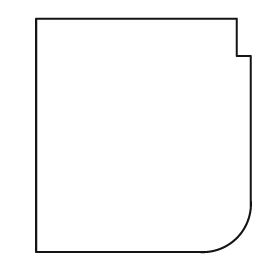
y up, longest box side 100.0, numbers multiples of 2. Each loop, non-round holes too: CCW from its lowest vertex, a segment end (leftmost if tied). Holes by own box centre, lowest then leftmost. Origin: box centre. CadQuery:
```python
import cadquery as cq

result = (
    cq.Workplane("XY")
    .moveTo(-46.0, -50.0)
    .lineTo(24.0, -50.0)
    .threePointArc((40.0, -44.0), (46.0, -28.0))
    .lineTo(46.0, 34.0)
    .lineTo(40.0, 34.0)
    .lineTo(40.0, 50.0)
    .lineTo(-46.0, 50.0)
    .close()
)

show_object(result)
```